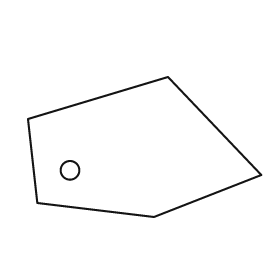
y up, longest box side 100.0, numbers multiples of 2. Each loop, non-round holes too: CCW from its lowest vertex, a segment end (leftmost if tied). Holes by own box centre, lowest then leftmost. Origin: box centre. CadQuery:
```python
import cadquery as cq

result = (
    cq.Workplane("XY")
    .moveTo(4.0, -30.0)
    .lineTo(50.0, -12.0)
    .lineTo(10.0, 30.0)
    .lineTo(-50.0, 12.0)
    .lineTo(-46.0, -24.0)
    .close()
    .moveTo(-32.0, -10.0)
    .circle(4.0)
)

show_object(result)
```